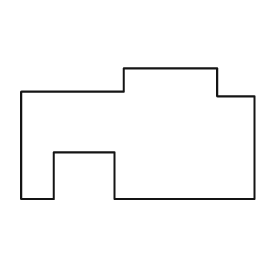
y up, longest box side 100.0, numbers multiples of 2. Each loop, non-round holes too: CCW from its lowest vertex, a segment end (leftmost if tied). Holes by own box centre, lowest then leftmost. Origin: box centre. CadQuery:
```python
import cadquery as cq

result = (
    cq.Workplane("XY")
    .moveTo(-50.0, -28.0)
    .lineTo(-36.0, -28.0)
    .lineTo(-36.0, -8.0)
    .lineTo(-10.0, -8.0)
    .lineTo(-10.0, -28.0)
    .lineTo(50.0, -28.0)
    .lineTo(50.0, 16.0)
    .lineTo(34.0, 16.0)
    .lineTo(34.0, 28.0)
    .lineTo(-6.0, 28.0)
    .lineTo(-6.0, 18.0)
    .lineTo(-50.0, 18.0)
    .close()
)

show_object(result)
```